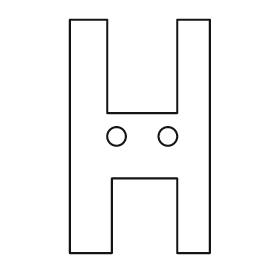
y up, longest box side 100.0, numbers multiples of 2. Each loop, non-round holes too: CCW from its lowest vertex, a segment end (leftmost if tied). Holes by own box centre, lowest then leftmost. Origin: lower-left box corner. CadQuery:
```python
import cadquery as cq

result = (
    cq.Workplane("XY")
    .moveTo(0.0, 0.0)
    .lineTo(18.0, 0.0)
    .lineTo(18.0, 32.0)
    .lineTo(46.0, 32.0)
    .lineTo(46.0, 0.0)
    .lineTo(60.0, 0.0)
    .lineTo(60.0, 100.0)
    .lineTo(46.0, 100.0)
    .lineTo(46.0, 60.0)
    .lineTo(16.0, 60.0)
    .lineTo(16.0, 100.0)
    .lineTo(0.0, 100.0)
    .close()
    .moveTo(20.0, 50.0)
    .circle(4.0)
    .moveTo(42.0, 50.0)
    .circle(4.0)
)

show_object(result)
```